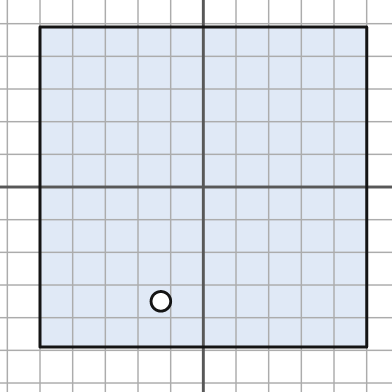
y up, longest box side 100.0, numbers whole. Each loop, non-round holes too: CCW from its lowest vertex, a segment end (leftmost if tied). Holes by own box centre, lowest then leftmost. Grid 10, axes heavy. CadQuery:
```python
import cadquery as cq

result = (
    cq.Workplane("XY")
    .moveTo(-50.0, -49.0)
    .lineTo(50.0, -49.0)
    .lineTo(50.0, 49.0)
    .lineTo(-50.0, 49.0)
    .close()
    .moveTo(-13.0, -35.0)
    .circle(3.0)
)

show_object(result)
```